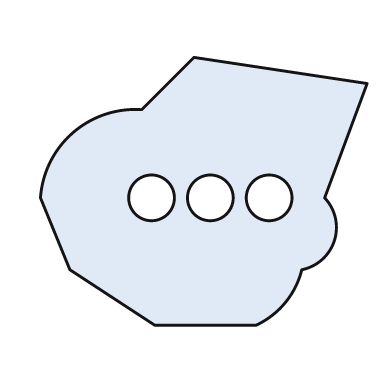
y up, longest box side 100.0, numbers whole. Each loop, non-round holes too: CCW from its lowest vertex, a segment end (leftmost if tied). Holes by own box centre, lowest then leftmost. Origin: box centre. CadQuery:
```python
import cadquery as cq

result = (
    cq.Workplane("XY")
    .moveTo(-15.0, -41.0)
    .lineTo(16.0, -41.0)
    .threePointArc((25.0, -34.0), (30.0, -24.0))
    .threePointArc((40.0, -15.0), (37.0, -2.0))
    .lineTo(50.0, 33.0)
    .lineTo(-3.0, 41.0)
    .lineTo(-19.0, 25.0)
    .threePointArc((-40.0, 18.0), (-50.0, -2.0))
    .lineTo(-41.0, -24.0)
    .close()
    .moveTo(-16.0, -2.0)
    .circle(7.0)
    .moveTo(2.0, -2.0)
    .circle(7.0)
    .moveTo(20.0, -2.0)
    .circle(7.0)
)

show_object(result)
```